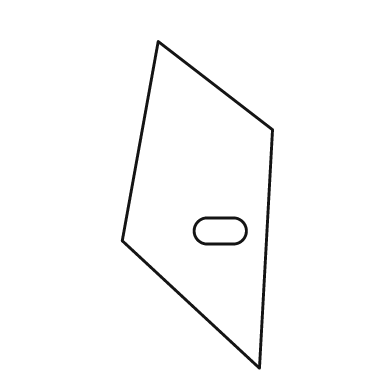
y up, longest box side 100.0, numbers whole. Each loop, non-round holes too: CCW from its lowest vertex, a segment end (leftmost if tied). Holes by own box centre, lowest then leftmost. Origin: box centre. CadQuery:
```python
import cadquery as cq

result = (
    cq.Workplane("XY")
    .moveTo(19.0, -50.0)
    .lineTo(23.0, 23.0)
    .lineTo(-12.0, 50.0)
    .lineTo(-23.0, -11.0)
    .close()
    .moveTo(3.0, -12.0)
    .lineTo(11.0, -12.0)
    .threePointArc((15.0, -8.0), (11.0, -4.0))
    .lineTo(3.0, -4.0)
    .threePointArc((-1.0, -8.0), (3.0, -12.0))
    .close()
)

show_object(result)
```